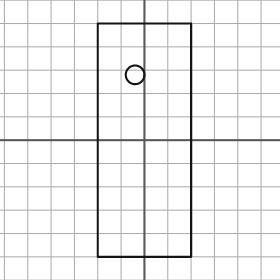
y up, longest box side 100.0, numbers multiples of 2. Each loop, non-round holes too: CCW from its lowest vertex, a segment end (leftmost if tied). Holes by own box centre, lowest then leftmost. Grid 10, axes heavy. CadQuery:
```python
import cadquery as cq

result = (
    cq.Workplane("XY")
    .moveTo(-20.0, -50.0)
    .lineTo(20.0, -50.0)
    .lineTo(20.0, 50.0)
    .lineTo(-20.0, 50.0)
    .close()
    .moveTo(-4.0, 28.0)
    .circle(4.0)
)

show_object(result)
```